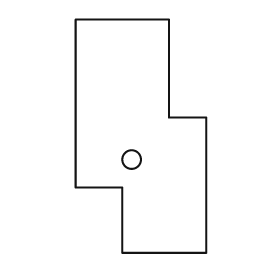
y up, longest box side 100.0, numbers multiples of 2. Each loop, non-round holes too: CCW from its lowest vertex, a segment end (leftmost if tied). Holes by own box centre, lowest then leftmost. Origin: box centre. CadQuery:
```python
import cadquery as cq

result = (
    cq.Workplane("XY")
    .moveTo(-8.0, -50.0)
    .lineTo(28.0, -50.0)
    .lineTo(28.0, 8.0)
    .lineTo(12.0, 8.0)
    .lineTo(12.0, 50.0)
    .lineTo(-28.0, 50.0)
    .lineTo(-28.0, -22.0)
    .lineTo(-8.0, -22.0)
    .close()
    .moveTo(-4.0, -10.0)
    .circle(4.0)
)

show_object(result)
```